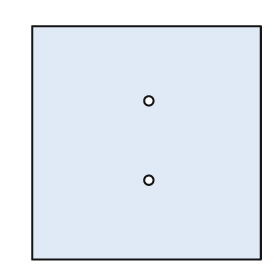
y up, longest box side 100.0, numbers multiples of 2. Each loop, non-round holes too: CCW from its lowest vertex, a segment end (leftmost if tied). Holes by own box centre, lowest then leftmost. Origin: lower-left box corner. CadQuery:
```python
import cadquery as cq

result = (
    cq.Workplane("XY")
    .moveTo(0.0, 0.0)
    .lineTo(98.0, 0.0)
    .lineTo(98.0, 100.0)
    .lineTo(0.0, 100.0)
    .close()
    .moveTo(50.0, 34.0)
    .circle(2.0)
    .moveTo(50.0, 68.0)
    .circle(2.0)
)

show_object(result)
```